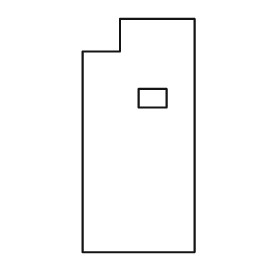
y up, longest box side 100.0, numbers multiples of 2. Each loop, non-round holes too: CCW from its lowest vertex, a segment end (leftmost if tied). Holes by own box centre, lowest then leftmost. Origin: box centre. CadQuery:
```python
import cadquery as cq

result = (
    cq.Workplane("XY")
    .moveTo(-24.0, -50.0)
    .lineTo(24.0, -50.0)
    .lineTo(24.0, 50.0)
    .lineTo(-8.0, 50.0)
    .lineTo(-8.0, 36.0)
    .lineTo(-24.0, 36.0)
    .close()
    .moveTo(0.0, 12.0)
    .lineTo(12.0, 12.0)
    .lineTo(12.0, 20.0)
    .lineTo(0.0, 20.0)
    .close()
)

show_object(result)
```